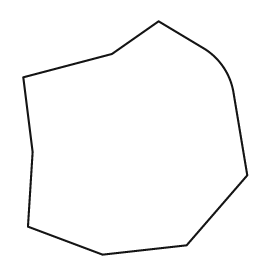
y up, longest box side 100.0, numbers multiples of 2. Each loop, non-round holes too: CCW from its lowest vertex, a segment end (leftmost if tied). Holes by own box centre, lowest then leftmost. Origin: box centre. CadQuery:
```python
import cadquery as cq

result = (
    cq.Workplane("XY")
    .moveTo(-14.0, -50.0)
    .lineTo(22.0, -46.0)
    .lineTo(48.0, -16.0)
    .lineTo(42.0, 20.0)
    .threePointArc((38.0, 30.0), (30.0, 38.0))
    .lineTo(10.0, 50.0)
    .lineTo(-10.0, 36.0)
    .lineTo(-48.0, 26.0)
    .lineTo(-44.0, -6.0)
    .lineTo(-46.0, -38.0)
    .close()
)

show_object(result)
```